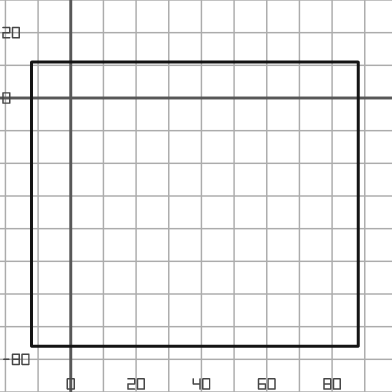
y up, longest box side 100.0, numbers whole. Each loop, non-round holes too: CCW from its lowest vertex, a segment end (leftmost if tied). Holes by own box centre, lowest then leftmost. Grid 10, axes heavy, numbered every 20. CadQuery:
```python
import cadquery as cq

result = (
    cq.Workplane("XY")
    .moveTo(-12.0, -76.0)
    .lineTo(88.0, -76.0)
    .lineTo(88.0, 11.0)
    .lineTo(-12.0, 11.0)
    .close()
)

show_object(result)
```